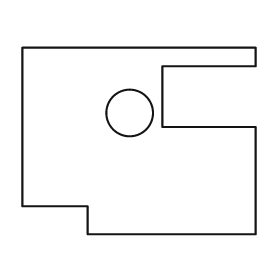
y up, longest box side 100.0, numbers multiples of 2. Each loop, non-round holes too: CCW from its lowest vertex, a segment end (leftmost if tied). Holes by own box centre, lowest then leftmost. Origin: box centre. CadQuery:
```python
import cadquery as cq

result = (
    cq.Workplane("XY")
    .moveTo(-22.0, -40.0)
    .lineTo(50.0, -40.0)
    .lineTo(50.0, 6.0)
    .lineTo(10.0, 6.0)
    .lineTo(10.0, 32.0)
    .lineTo(50.0, 32.0)
    .lineTo(50.0, 40.0)
    .lineTo(-50.0, 40.0)
    .lineTo(-50.0, -28.0)
    .lineTo(-22.0, -28.0)
    .close()
    .moveTo(-4.0, 12.0)
    .circle(10.0)
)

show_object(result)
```